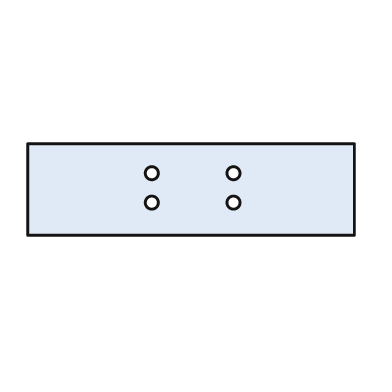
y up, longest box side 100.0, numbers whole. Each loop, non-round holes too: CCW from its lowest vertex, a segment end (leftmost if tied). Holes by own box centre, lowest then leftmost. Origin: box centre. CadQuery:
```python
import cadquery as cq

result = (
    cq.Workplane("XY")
    .moveTo(-50.0, -14.0)
    .lineTo(50.0, -14.0)
    .lineTo(50.0, 14.0)
    .lineTo(-50.0, 14.0)
    .close()
    .moveTo(-12.0, -4.0)
    .circle(2.0)
    .moveTo(13.0, -4.0)
    .circle(2.0)
    .moveTo(-12.0, 5.0)
    .circle(2.0)
    .moveTo(13.0, 5.0)
    .circle(2.0)
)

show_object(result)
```